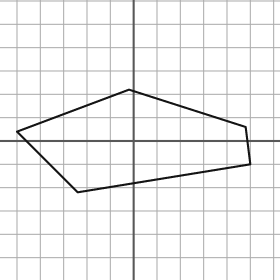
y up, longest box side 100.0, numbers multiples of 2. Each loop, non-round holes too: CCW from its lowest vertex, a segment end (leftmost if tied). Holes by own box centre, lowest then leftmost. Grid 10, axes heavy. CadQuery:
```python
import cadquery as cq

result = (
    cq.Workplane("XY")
    .moveTo(-24.0, -22.0)
    .lineTo(50.0, -10.0)
    .lineTo(48.0, 6.0)
    .lineTo(-2.0, 22.0)
    .lineTo(-50.0, 4.0)
    .close()
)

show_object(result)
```